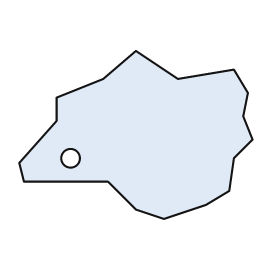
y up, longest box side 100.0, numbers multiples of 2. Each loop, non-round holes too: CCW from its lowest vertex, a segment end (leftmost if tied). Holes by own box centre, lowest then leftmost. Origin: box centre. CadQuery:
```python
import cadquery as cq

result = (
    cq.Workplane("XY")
    .moveTo(12.0, -36.0)
    .lineTo(30.0, -30.0)
    .lineTo(40.0, -24.0)
    .lineTo(42.0, -10.0)
    .lineTo(50.0, -2.0)
    .lineTo(46.0, 8.0)
    .lineTo(48.0, 18.0)
    .lineTo(42.0, 28.0)
    .lineTo(18.0, 24.0)
    .lineTo(0.0, 36.0)
    .lineTo(-14.0, 24.0)
    .lineTo(-34.0, 16.0)
    .lineTo(-34.0, 6.0)
    .lineTo(-50.0, -12.0)
    .lineTo(-48.0, -20.0)
    .lineTo(-12.0, -20.0)
    .lineTo(0.0, -32.0)
    .close()
    .moveTo(-28.0, -10.0)
    .circle(4.0)
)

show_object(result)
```